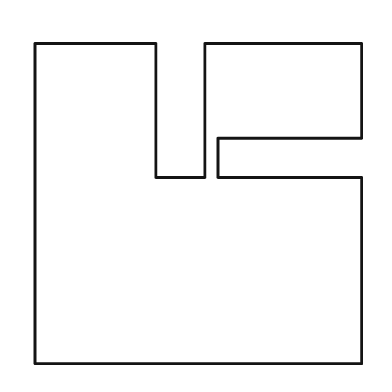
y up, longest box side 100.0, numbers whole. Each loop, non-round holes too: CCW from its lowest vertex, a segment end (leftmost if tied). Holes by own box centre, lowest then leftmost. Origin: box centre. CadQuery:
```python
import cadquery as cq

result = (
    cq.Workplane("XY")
    .moveTo(-50.0, -49.0)
    .lineTo(50.0, -49.0)
    .lineTo(50.0, 8.0)
    .lineTo(6.0, 8.0)
    .lineTo(6.0, 20.0)
    .lineTo(50.0, 20.0)
    .lineTo(50.0, 49.0)
    .lineTo(2.0, 49.0)
    .lineTo(2.0, 8.0)
    .lineTo(-13.0, 8.0)
    .lineTo(-13.0, 49.0)
    .lineTo(-50.0, 49.0)
    .close()
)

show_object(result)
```